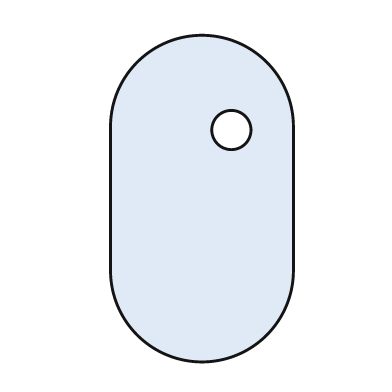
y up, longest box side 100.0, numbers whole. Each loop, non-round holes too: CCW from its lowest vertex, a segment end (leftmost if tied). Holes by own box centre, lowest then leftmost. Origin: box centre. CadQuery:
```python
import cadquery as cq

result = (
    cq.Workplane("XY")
    .moveTo(-28.0, -22.0)
    .threePointArc((0.0, -50.0), (28.0, -22.0))
    .lineTo(28.0, 22.0)
    .threePointArc((0.0, 50.0), (-28.0, 22.0))
    .close()
    .moveTo(9.0, 21.0)
    .circle(6.0)
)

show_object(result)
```